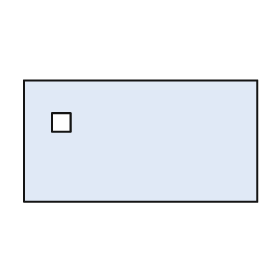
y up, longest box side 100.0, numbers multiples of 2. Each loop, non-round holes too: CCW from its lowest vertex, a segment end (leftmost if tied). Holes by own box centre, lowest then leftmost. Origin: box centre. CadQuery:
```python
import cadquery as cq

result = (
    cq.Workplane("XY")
    .moveTo(-50.0, -26.0)
    .lineTo(50.0, -26.0)
    .lineTo(50.0, 26.0)
    .lineTo(-50.0, 26.0)
    .close()
    .moveTo(-38.0, 4.0)
    .lineTo(-30.0, 4.0)
    .lineTo(-30.0, 12.0)
    .lineTo(-38.0, 12.0)
    .close()
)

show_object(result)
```